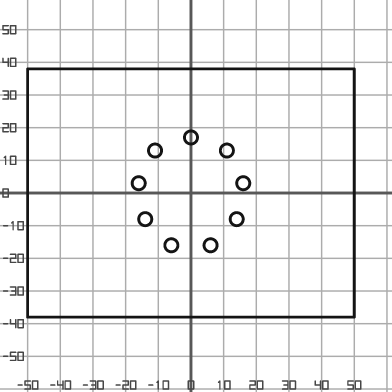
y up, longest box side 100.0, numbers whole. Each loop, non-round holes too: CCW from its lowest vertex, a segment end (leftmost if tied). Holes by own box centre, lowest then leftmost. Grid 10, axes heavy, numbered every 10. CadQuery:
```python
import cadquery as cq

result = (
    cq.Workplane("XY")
    .moveTo(-50.0, -38.0)
    .lineTo(50.0, -38.0)
    .lineTo(50.0, 38.0)
    .lineTo(-50.0, 38.0)
    .close()
    .moveTo(-6.0, -16.0)
    .circle(2.0)
    .moveTo(6.0, -16.0)
    .circle(2.0)
    .moveTo(-14.0, -8.0)
    .circle(2.0)
    .moveTo(14.0, -8.0)
    .circle(2.0)
    .moveTo(-16.0, 3.0)
    .circle(2.0)
    .moveTo(16.0, 3.0)
    .circle(2.0)
    .moveTo(-11.0, 13.0)
    .circle(2.0)
    .moveTo(11.0, 13.0)
    .circle(2.0)
    .moveTo(0.0, 17.0)
    .circle(2.0)
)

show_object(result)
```